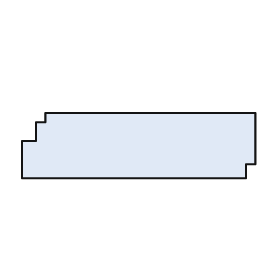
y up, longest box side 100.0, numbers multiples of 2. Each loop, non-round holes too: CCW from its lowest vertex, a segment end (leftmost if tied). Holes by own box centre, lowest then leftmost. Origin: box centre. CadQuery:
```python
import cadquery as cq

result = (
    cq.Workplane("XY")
    .moveTo(-50.0, -14.0)
    .lineTo(46.0, -14.0)
    .lineTo(46.0, -8.0)
    .lineTo(50.0, -8.0)
    .lineTo(50.0, 14.0)
    .lineTo(-40.0, 14.0)
    .lineTo(-40.0, 10.0)
    .lineTo(-44.0, 10.0)
    .lineTo(-44.0, 2.0)
    .lineTo(-50.0, 2.0)
    .close()
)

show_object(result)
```